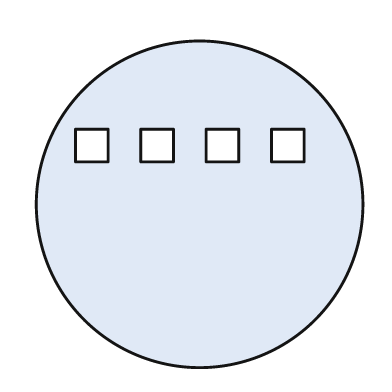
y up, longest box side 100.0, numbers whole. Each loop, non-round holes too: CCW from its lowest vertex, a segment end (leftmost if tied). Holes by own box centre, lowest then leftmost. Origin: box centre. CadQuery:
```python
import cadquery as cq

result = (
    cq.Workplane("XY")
    .moveTo(0.0, 0.0)
    .circle(50.0)
    .moveTo(-38.0, 13.0)
    .lineTo(-28.0, 13.0)
    .lineTo(-28.0, 23.0)
    .lineTo(-38.0, 23.0)
    .close()
    .moveTo(-18.0, 13.0)
    .lineTo(-8.0, 13.0)
    .lineTo(-8.0, 23.0)
    .lineTo(-18.0, 23.0)
    .close()
    .moveTo(2.0, 13.0)
    .lineTo(12.0, 13.0)
    .lineTo(12.0, 23.0)
    .lineTo(2.0, 23.0)
    .close()
    .moveTo(22.0, 13.0)
    .lineTo(32.0, 13.0)
    .lineTo(32.0, 23.0)
    .lineTo(22.0, 23.0)
    .close()
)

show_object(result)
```